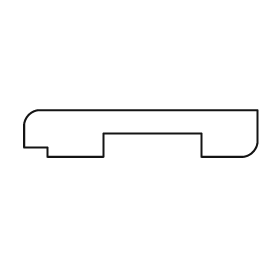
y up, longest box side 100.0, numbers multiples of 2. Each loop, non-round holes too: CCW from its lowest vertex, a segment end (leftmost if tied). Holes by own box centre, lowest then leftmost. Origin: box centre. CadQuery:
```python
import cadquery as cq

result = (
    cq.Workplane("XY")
    .moveTo(-40.0, -10.0)
    .lineTo(-16.0, -10.0)
    .lineTo(-16.0, 0.0)
    .lineTo(26.0, 0.0)
    .lineTo(26.0, -10.0)
    .lineTo(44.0, -10.0)
    .threePointArc((48.0, -8.0), (50.0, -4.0))
    .lineTo(50.0, 10.0)
    .lineTo(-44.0, 10.0)
    .threePointArc((-48.0, 8.0), (-50.0, 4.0))
    .lineTo(-50.0, -6.0)
    .lineTo(-40.0, -6.0)
    .close()
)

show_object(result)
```